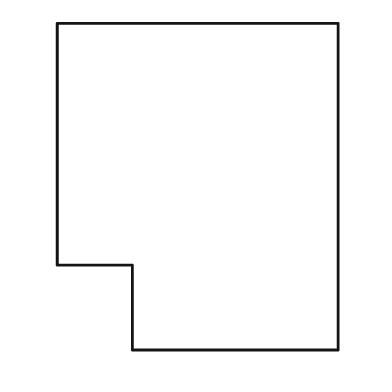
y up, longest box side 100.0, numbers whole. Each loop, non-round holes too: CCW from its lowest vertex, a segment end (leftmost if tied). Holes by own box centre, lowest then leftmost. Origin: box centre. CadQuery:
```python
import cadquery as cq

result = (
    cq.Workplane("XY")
    .moveTo(-20.0, -50.0)
    .lineTo(43.0, -50.0)
    .lineTo(43.0, 50.0)
    .lineTo(-43.0, 50.0)
    .lineTo(-43.0, -24.0)
    .lineTo(-20.0, -24.0)
    .close()
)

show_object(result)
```